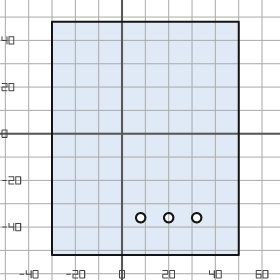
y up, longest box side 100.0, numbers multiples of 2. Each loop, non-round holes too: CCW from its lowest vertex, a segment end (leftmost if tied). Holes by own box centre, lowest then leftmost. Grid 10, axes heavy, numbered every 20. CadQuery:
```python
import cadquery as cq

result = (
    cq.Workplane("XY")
    .moveTo(-30.0, -52.0)
    .lineTo(50.0, -52.0)
    .lineTo(50.0, 48.0)
    .lineTo(-30.0, 48.0)
    .close()
    .moveTo(8.0, -36.0)
    .circle(2.0)
    .moveTo(20.0, -36.0)
    .circle(2.0)
    .moveTo(32.0, -36.0)
    .circle(2.0)
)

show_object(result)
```